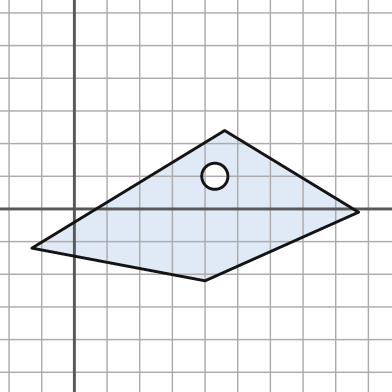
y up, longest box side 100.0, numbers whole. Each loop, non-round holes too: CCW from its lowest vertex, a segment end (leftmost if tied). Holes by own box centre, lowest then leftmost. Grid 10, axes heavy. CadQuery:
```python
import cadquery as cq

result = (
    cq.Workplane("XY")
    .moveTo(40.0, -22.0)
    .lineTo(87.0, -1.0)
    .lineTo(46.0, 24.0)
    .lineTo(-13.0, -12.0)
    .close()
    .moveTo(43.0, 10.0)
    .circle(4.0)
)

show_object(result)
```